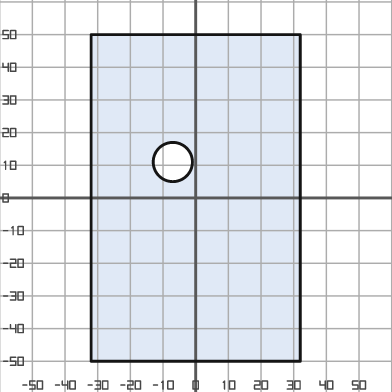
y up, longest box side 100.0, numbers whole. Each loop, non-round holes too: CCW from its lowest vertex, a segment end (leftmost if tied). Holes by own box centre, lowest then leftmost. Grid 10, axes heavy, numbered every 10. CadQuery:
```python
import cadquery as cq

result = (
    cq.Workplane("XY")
    .moveTo(-32.0, -50.0)
    .lineTo(32.0, -50.0)
    .lineTo(32.0, 50.0)
    .lineTo(-32.0, 50.0)
    .close()
    .moveTo(-7.0, 11.0)
    .circle(6.0)
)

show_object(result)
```